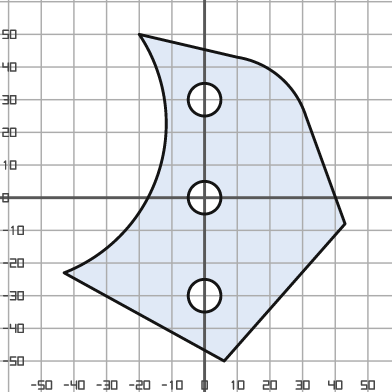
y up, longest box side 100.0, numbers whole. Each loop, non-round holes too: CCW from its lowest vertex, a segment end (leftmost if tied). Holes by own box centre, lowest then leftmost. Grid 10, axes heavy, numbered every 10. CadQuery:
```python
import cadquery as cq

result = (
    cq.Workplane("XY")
    .moveTo(6.0, -50.0)
    .lineTo(43.0, -8.0)
    .lineTo(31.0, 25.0)
    .threePointArc((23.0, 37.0), (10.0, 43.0))
    .lineTo(-20.0, 50.0)
    .threePointArc((-14.0, 8.0), (-43.0, -23.0))
    .close()
    .moveTo(0.0, -30.0)
    .circle(5.0)
    .moveTo(0.0, 0.0)
    .circle(5.0)
    .moveTo(0.0, 30.0)
    .circle(5.0)
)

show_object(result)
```